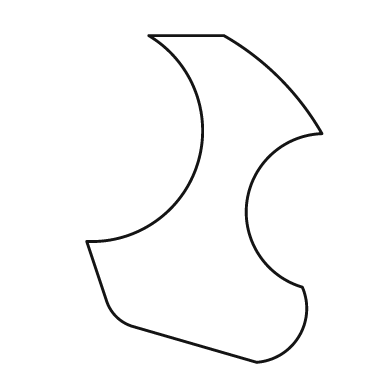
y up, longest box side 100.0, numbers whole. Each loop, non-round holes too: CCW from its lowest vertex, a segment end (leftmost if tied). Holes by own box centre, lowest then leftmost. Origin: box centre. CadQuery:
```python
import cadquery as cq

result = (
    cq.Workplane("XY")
    .moveTo(16.0, -50.0)
    .threePointArc((29.0, -42.0), (30.0, -27.0))
    .threePointArc((13.0, -1.0), (36.0, 20.0))
    .threePointArc((23.0, 37.0), (6.0, 50.0))
    .lineTo(-17.0, 50.0)
    .threePointArc((-2.0, 11.0), (-36.0, -13.0))
    .lineTo(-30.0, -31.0)
    .threePointArc((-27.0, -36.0), (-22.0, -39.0))
    .close()
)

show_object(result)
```